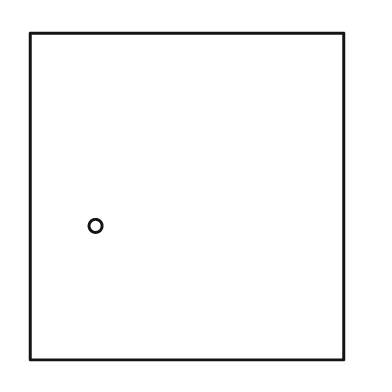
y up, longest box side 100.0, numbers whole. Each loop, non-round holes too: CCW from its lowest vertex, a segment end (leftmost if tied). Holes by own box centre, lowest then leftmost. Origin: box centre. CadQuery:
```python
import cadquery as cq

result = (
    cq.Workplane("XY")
    .moveTo(-48.0, -50.0)
    .lineTo(48.0, -50.0)
    .lineTo(48.0, 50.0)
    .lineTo(-48.0, 50.0)
    .close()
    .moveTo(-28.0, -9.0)
    .circle(2.0)
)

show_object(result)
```